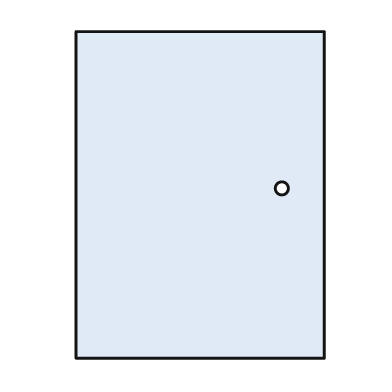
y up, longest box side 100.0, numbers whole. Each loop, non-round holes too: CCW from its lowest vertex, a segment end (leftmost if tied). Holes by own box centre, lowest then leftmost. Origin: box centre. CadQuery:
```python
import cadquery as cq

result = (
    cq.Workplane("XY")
    .moveTo(-38.0, -50.0)
    .lineTo(38.0, -50.0)
    .lineTo(38.0, 50.0)
    .lineTo(-38.0, 50.0)
    .close()
    .moveTo(25.0, 2.0)
    .circle(2.0)
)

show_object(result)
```